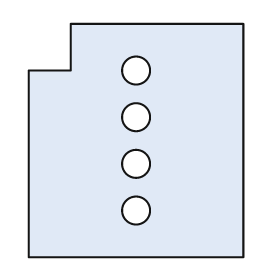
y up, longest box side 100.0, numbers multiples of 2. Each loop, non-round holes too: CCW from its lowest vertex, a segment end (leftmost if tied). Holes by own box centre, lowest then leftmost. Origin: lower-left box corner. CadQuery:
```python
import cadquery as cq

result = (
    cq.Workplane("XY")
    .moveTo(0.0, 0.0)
    .lineTo(92.0, 0.0)
    .lineTo(92.0, 100.0)
    .lineTo(18.0, 100.0)
    .lineTo(18.0, 80.0)
    .lineTo(0.0, 80.0)
    .close()
    .moveTo(46.0, 20.0)
    .circle(6.0)
    .moveTo(46.0, 40.0)
    .circle(6.0)
    .moveTo(46.0, 60.0)
    .circle(6.0)
    .moveTo(46.0, 80.0)
    .circle(6.0)
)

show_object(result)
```